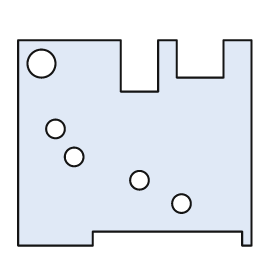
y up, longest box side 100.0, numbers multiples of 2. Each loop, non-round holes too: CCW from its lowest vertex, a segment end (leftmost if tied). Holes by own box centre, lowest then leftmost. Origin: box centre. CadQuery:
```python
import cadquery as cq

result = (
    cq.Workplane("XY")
    .moveTo(-50.0, -44.0)
    .lineTo(-18.0, -44.0)
    .lineTo(-18.0, -38.0)
    .lineTo(46.0, -38.0)
    .lineTo(46.0, -44.0)
    .lineTo(50.0, -44.0)
    .lineTo(50.0, 44.0)
    .lineTo(38.0, 44.0)
    .lineTo(38.0, 28.0)
    .lineTo(18.0, 28.0)
    .lineTo(18.0, 44.0)
    .lineTo(10.0, 44.0)
    .lineTo(10.0, 22.0)
    .lineTo(-6.0, 22.0)
    .lineTo(-6.0, 44.0)
    .lineTo(-50.0, 44.0)
    .close()
    .moveTo(20.0, -26.0)
    .circle(4.0)
    .moveTo(2.0, -16.0)
    .circle(4.0)
    .moveTo(-26.0, -6.0)
    .circle(4.0)
    .moveTo(-34.0, 6.0)
    .circle(4.0)
    .moveTo(-40.0, 34.0)
    .circle(6.0)
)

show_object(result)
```